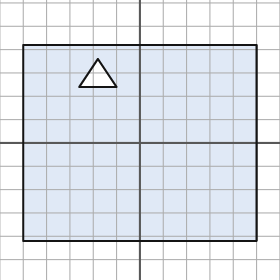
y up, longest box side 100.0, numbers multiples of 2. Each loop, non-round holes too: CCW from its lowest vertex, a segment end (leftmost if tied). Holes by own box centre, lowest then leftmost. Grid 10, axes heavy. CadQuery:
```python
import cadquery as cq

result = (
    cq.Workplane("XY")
    .moveTo(-50.0, -42.0)
    .lineTo(50.0, -42.0)
    .lineTo(50.0, 42.0)
    .lineTo(-50.0, 42.0)
    .close()
    .moveTo(-26.0, 24.0)
    .lineTo(-10.0, 24.0)
    .lineTo(-18.0, 36.0)
    .close()
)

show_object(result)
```